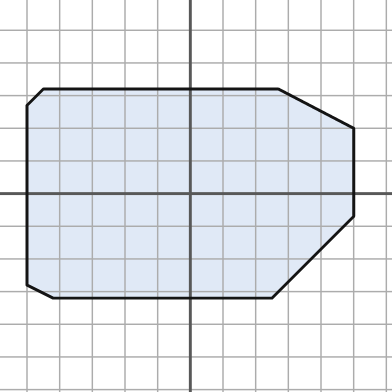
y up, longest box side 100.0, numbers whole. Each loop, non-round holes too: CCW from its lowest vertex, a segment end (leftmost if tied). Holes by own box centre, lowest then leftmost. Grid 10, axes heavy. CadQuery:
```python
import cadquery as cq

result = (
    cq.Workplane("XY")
    .moveTo(-42.0, -32.0)
    .lineTo(25.0, -32.0)
    .lineTo(50.0, -7.0)
    .lineTo(50.0, 20.0)
    .lineTo(27.0, 32.0)
    .lineTo(-45.0, 32.0)
    .lineTo(-50.0, 27.0)
    .lineTo(-50.0, -28.0)
    .close()
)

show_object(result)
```